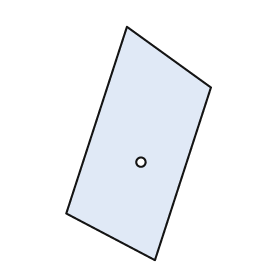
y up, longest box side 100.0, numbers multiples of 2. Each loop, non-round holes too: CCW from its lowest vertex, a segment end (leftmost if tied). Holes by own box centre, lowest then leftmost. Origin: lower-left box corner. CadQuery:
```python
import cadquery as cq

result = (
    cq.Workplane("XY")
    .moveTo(38.0, 0.0)
    .lineTo(62.0, 74.0)
    .lineTo(26.0, 100.0)
    .lineTo(0.0, 20.0)
    .close()
    .moveTo(32.0, 42.0)
    .circle(2.0)
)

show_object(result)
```